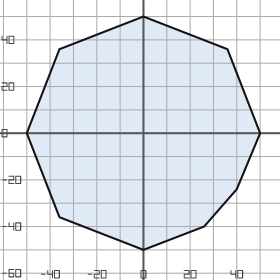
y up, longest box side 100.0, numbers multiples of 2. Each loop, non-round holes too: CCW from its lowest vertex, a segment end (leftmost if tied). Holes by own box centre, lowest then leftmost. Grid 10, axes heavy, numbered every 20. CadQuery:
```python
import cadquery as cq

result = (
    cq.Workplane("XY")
    .moveTo(0.0, -50.0)
    .lineTo(26.0, -40.0)
    .lineTo(40.0, -24.0)
    .lineTo(50.0, 0.0)
    .lineTo(36.0, 36.0)
    .lineTo(0.0, 50.0)
    .lineTo(-36.0, 36.0)
    .lineTo(-50.0, 0.0)
    .lineTo(-36.0, -36.0)
    .close()
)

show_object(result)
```